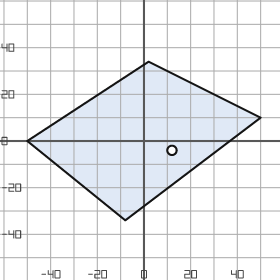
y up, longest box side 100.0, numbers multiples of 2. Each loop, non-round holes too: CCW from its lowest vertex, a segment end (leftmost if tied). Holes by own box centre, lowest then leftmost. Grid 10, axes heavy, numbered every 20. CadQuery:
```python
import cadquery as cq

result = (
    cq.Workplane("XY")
    .moveTo(-8.0, -34.0)
    .lineTo(50.0, 10.0)
    .lineTo(2.0, 34.0)
    .lineTo(-50.0, 0.0)
    .close()
    .moveTo(12.0, -4.0)
    .circle(2.0)
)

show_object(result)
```